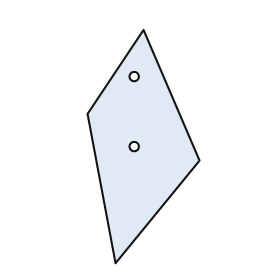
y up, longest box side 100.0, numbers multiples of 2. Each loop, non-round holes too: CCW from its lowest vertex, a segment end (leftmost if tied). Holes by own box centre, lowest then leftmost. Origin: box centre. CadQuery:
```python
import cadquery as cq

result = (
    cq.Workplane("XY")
    .moveTo(-12.0, -50.0)
    .lineTo(24.0, -6.0)
    .lineTo(0.0, 50.0)
    .lineTo(-24.0, 14.0)
    .close()
    .moveTo(-4.0, 0.0)
    .circle(2.0)
    .moveTo(-4.0, 30.0)
    .circle(2.0)
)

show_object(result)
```